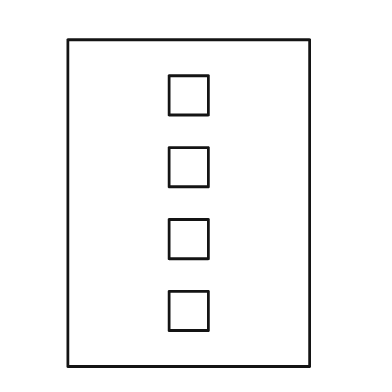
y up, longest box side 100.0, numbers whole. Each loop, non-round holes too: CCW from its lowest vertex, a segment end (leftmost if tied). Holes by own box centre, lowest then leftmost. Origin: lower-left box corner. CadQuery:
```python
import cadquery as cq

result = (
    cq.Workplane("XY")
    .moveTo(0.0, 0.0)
    .lineTo(74.0, 0.0)
    .lineTo(74.0, 100.0)
    .lineTo(0.0, 100.0)
    .close()
    .moveTo(31.0, 11.0)
    .lineTo(43.0, 11.0)
    .lineTo(43.0, 23.0)
    .lineTo(31.0, 23.0)
    .close()
    .moveTo(31.0, 33.0)
    .lineTo(43.0, 33.0)
    .lineTo(43.0, 45.0)
    .lineTo(31.0, 45.0)
    .close()
    .moveTo(31.0, 55.0)
    .lineTo(43.0, 55.0)
    .lineTo(43.0, 67.0)
    .lineTo(31.0, 67.0)
    .close()
    .moveTo(31.0, 77.0)
    .lineTo(43.0, 77.0)
    .lineTo(43.0, 89.0)
    .lineTo(31.0, 89.0)
    .close()
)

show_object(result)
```